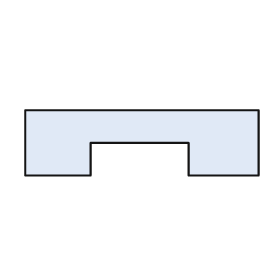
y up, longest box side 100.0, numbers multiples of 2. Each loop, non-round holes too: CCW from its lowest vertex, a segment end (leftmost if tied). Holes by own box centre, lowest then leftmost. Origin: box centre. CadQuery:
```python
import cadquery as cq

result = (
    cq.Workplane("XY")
    .moveTo(-50.0, -14.0)
    .lineTo(-22.0, -14.0)
    .lineTo(-22.0, 0.0)
    .lineTo(20.0, 0.0)
    .lineTo(20.0, -14.0)
    .lineTo(50.0, -14.0)
    .lineTo(50.0, 14.0)
    .lineTo(-50.0, 14.0)
    .close()
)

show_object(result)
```